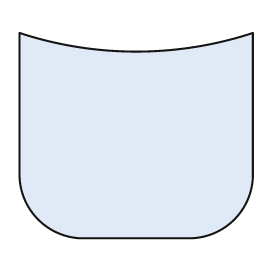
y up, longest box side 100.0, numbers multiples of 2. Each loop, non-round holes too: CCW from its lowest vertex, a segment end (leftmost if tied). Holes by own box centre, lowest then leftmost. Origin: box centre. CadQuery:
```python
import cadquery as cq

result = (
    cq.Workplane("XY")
    .moveTo(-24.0, -44.0)
    .lineTo(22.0, -44.0)
    .threePointArc((42.0, -36.0), (50.0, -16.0))
    .lineTo(50.0, 44.0)
    .threePointArc((0.0, 36.0), (-50.0, 44.0))
    .lineTo(-50.0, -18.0)
    .threePointArc((-42.0, -36.0), (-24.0, -44.0))
    .close()
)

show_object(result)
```